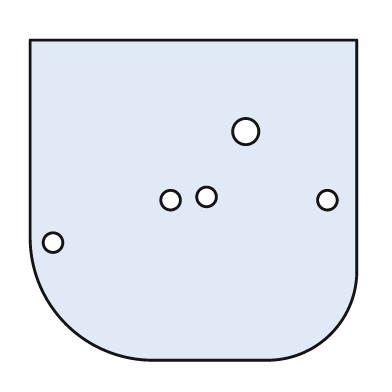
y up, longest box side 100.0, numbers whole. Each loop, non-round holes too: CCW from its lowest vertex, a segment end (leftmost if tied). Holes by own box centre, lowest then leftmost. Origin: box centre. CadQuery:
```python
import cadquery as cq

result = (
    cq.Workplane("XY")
    .moveTo(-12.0, -49.0)
    .lineTo(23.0, -49.0)
    .threePointArc((42.0, -41.0), (50.0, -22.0))
    .lineTo(50.0, 49.0)
    .lineTo(-50.0, 49.0)
    .lineTo(-50.0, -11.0)
    .threePointArc((-39.0, -38.0), (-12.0, -49.0))
    .close()
    .moveTo(-43.0, -13.0)
    .circle(3.0)
    .moveTo(-7.0, 0.0)
    .circle(3.0)
    .moveTo(41.0, 0.0)
    .circle(3.0)
    .moveTo(4.0, 1.0)
    .circle(3.0)
    .moveTo(16.0, 21.0)
    .circle(4.0)
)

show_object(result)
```